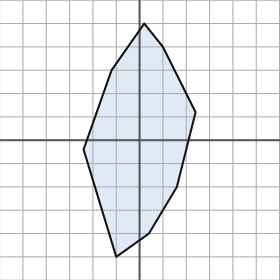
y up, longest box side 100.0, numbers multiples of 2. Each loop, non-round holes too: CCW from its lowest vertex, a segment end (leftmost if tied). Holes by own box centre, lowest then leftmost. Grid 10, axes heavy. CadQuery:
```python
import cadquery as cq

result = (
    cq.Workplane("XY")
    .moveTo(-10.0, -50.0)
    .lineTo(4.0, -40.0)
    .lineTo(16.0, -20.0)
    .lineTo(24.0, 12.0)
    .lineTo(10.0, 40.0)
    .lineTo(2.0, 50.0)
    .lineTo(-12.0, 30.0)
    .lineTo(-24.0, -4.0)
    .close()
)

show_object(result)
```